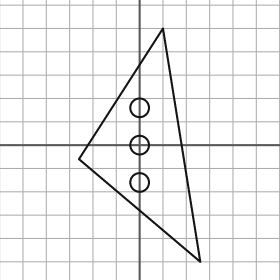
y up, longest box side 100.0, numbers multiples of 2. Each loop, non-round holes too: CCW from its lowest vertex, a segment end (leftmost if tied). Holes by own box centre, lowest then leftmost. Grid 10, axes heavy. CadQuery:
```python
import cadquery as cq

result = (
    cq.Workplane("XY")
    .moveTo(26.0, -50.0)
    .lineTo(10.0, 50.0)
    .lineTo(-26.0, -6.0)
    .close()
    .moveTo(0.0, -16.0)
    .circle(4.0)
    .moveTo(0.0, 0.0)
    .circle(4.0)
    .moveTo(0.0, 16.0)
    .circle(4.0)
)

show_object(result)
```